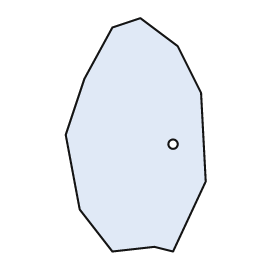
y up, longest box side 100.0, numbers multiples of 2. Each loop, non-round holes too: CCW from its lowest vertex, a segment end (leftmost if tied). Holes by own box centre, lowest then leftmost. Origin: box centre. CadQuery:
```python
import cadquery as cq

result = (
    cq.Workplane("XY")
    .moveTo(-10.0, -50.0)
    .lineTo(8.0, -48.0)
    .lineTo(16.0, -50.0)
    .lineTo(30.0, -20.0)
    .lineTo(28.0, 18.0)
    .lineTo(18.0, 38.0)
    .lineTo(2.0, 50.0)
    .lineTo(-10.0, 46.0)
    .lineTo(-22.0, 24.0)
    .lineTo(-30.0, 0.0)
    .lineTo(-24.0, -32.0)
    .close()
    .moveTo(16.0, -4.0)
    .circle(2.0)
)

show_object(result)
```